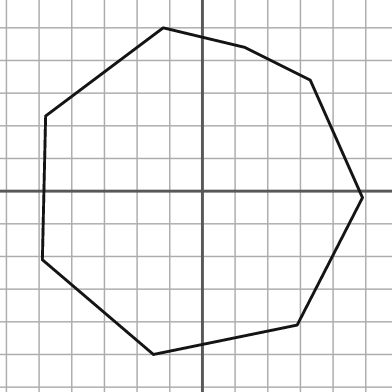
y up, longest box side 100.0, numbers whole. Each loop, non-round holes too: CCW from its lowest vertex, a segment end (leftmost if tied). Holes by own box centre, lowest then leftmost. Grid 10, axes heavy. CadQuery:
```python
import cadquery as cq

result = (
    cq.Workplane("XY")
    .moveTo(-15.0, -50.0)
    .lineTo(29.0, -41.0)
    .lineTo(49.0, -2.0)
    .lineTo(33.0, 34.0)
    .lineTo(13.0, 44.0)
    .lineTo(-12.0, 50.0)
    .lineTo(-48.0, 23.0)
    .lineTo(-49.0, -21.0)
    .close()
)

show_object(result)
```